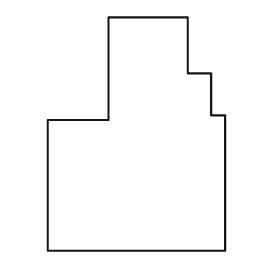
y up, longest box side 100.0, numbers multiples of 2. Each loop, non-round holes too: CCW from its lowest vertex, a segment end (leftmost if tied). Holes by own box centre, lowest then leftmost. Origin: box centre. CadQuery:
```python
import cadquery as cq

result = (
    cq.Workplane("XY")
    .moveTo(-38.0, -50.0)
    .lineTo(38.0, -50.0)
    .lineTo(38.0, 8.0)
    .lineTo(32.0, 8.0)
    .lineTo(32.0, 26.0)
    .lineTo(22.0, 26.0)
    .lineTo(22.0, 50.0)
    .lineTo(-12.0, 50.0)
    .lineTo(-12.0, 6.0)
    .lineTo(-38.0, 6.0)
    .close()
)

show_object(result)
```